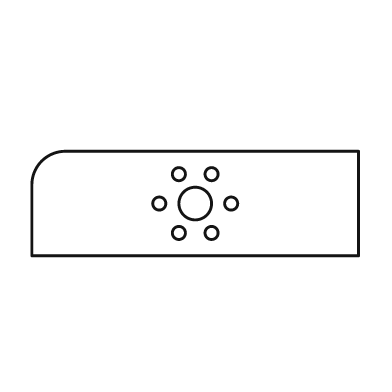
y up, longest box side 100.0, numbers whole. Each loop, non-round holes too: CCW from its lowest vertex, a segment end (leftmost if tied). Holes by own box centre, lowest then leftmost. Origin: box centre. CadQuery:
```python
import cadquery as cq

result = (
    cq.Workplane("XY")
    .moveTo(-50.0, -16.0)
    .lineTo(50.0, -16.0)
    .lineTo(50.0, 16.0)
    .lineTo(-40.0, 16.0)
    .threePointArc((-47.0, 13.0), (-50.0, 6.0))
    .close()
    .moveTo(-5.0, -9.0)
    .circle(2.0)
    .moveTo(5.0, -9.0)
    .circle(2.0)
    .moveTo(-11.0, 0.0)
    .circle(2.0)
    .moveTo(0.0, 0.0)
    .circle(5.0)
    .moveTo(11.0, 0.0)
    .circle(2.0)
    .moveTo(-5.0, 9.0)
    .circle(2.0)
    .moveTo(5.0, 9.0)
    .circle(2.0)
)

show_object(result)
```